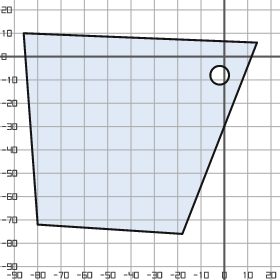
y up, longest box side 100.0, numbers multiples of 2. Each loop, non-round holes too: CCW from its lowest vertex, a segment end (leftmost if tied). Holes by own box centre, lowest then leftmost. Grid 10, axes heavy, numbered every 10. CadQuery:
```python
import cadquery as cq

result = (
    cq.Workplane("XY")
    .moveTo(-18.0, -76.0)
    .lineTo(14.0, 6.0)
    .lineTo(-86.0, 10.0)
    .lineTo(-80.0, -72.0)
    .close()
    .moveTo(-2.0, -8.0)
    .circle(4.0)
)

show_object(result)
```